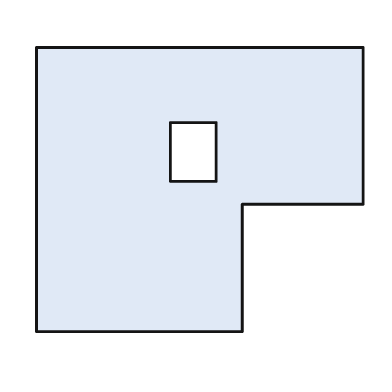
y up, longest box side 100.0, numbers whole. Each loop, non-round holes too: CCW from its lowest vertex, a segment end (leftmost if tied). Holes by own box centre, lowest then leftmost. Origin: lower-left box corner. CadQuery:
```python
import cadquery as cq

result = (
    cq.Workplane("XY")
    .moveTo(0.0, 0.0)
    .lineTo(63.0, 0.0)
    .lineTo(63.0, 39.0)
    .lineTo(100.0, 39.0)
    .lineTo(100.0, 87.0)
    .lineTo(0.0, 87.0)
    .close()
    .moveTo(41.0, 46.0)
    .lineTo(55.0, 46.0)
    .lineTo(55.0, 64.0)
    .lineTo(41.0, 64.0)
    .close()
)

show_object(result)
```